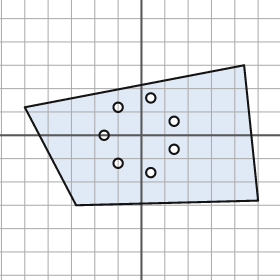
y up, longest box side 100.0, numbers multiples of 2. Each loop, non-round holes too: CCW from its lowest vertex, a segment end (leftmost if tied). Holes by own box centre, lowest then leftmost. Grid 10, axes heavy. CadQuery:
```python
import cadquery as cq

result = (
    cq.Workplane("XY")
    .moveTo(-28.0, -30.0)
    .lineTo(50.0, -28.0)
    .lineTo(44.0, 30.0)
    .lineTo(-50.0, 12.0)
    .close()
    .moveTo(4.0, -16.0)
    .circle(2.0)
    .moveTo(-10.0, -12.0)
    .circle(2.0)
    .moveTo(14.0, -6.0)
    .circle(2.0)
    .moveTo(-16.0, 0.0)
    .circle(2.0)
    .moveTo(14.0, 6.0)
    .circle(2.0)
    .moveTo(-10.0, 12.0)
    .circle(2.0)
    .moveTo(4.0, 16.0)
    .circle(2.0)
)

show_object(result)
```